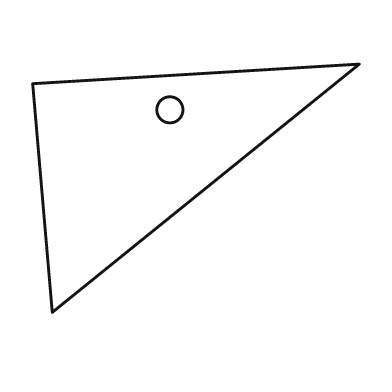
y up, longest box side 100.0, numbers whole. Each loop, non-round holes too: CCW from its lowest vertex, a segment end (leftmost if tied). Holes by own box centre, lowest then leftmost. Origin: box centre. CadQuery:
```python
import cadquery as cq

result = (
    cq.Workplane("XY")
    .moveTo(-44.0, -38.0)
    .lineTo(50.0, 38.0)
    .lineTo(-50.0, 32.0)
    .close()
    .moveTo(-8.0, 24.0)
    .circle(4.0)
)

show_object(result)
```